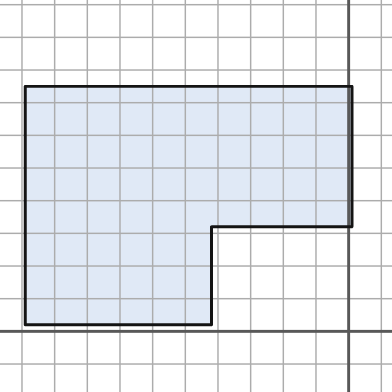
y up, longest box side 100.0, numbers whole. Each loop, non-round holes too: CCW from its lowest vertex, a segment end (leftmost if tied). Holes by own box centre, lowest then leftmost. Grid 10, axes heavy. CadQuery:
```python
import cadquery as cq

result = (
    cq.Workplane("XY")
    .moveTo(-99.0, 2.0)
    .lineTo(-42.0, 2.0)
    .lineTo(-42.0, 32.0)
    .lineTo(1.0, 32.0)
    .lineTo(1.0, 75.0)
    .lineTo(-99.0, 75.0)
    .close()
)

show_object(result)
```